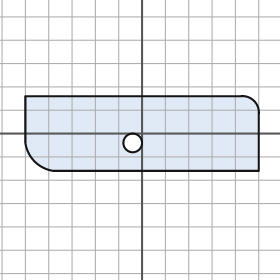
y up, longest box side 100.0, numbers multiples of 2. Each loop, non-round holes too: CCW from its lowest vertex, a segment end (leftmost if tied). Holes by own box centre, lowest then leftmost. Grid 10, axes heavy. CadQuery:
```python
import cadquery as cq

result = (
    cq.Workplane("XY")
    .moveTo(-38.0, -16.0)
    .lineTo(50.0, -16.0)
    .lineTo(50.0, 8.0)
    .threePointArc((48.0, 14.0), (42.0, 16.0))
    .lineTo(-50.0, 16.0)
    .lineTo(-50.0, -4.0)
    .threePointArc((-46.0, -12.0), (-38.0, -16.0))
    .close()
    .moveTo(-4.0, -4.0)
    .circle(4.0)
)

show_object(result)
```